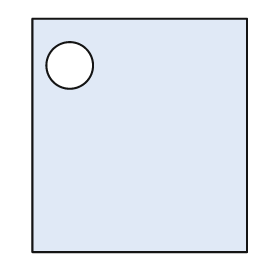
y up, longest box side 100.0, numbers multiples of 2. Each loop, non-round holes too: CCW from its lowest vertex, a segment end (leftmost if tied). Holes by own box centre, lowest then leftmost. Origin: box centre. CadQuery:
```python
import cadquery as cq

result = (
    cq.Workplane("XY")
    .moveTo(-46.0, -50.0)
    .lineTo(46.0, -50.0)
    .lineTo(46.0, 50.0)
    .lineTo(-46.0, 50.0)
    .close()
    .moveTo(-30.0, 30.0)
    .circle(10.0)
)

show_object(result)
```